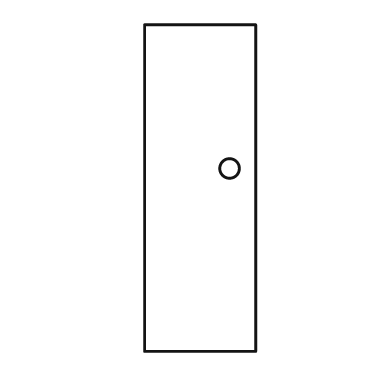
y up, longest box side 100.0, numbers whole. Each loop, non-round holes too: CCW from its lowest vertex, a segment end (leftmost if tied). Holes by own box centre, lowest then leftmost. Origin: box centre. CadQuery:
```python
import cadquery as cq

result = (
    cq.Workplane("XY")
    .moveTo(-17.0, -50.0)
    .lineTo(17.0, -50.0)
    .lineTo(17.0, 50.0)
    .lineTo(-17.0, 50.0)
    .close()
    .moveTo(9.0, 6.0)
    .circle(3.0)
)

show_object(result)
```